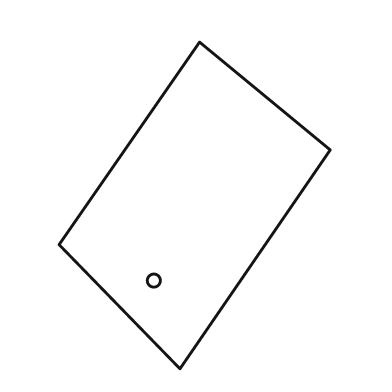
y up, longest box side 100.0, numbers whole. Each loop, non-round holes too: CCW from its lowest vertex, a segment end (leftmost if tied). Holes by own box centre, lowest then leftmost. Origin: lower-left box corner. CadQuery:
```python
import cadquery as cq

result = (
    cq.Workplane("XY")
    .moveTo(37.0, 0.0)
    .lineTo(83.0, 67.0)
    .lineTo(43.0, 100.0)
    .lineTo(0.0, 38.0)
    .close()
    .moveTo(29.0, 27.0)
    .circle(2.0)
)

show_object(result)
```